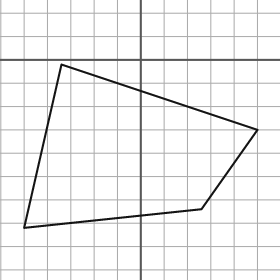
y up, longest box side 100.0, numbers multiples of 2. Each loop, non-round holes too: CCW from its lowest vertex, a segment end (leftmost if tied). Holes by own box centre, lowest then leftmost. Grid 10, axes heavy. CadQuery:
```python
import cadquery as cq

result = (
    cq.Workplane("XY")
    .moveTo(-50.0, -72.0)
    .lineTo(26.0, -64.0)
    .lineTo(50.0, -30.0)
    .lineTo(-34.0, -2.0)
    .close()
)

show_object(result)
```